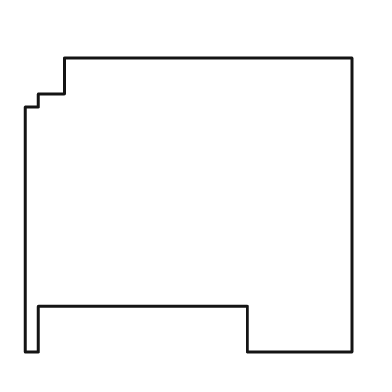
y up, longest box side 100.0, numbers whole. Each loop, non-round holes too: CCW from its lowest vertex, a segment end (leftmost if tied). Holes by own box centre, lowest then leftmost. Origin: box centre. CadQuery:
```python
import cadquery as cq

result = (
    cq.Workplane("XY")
    .moveTo(-50.0, -45.0)
    .lineTo(-46.0, -45.0)
    .lineTo(-46.0, -31.0)
    .lineTo(18.0, -31.0)
    .lineTo(18.0, -45.0)
    .lineTo(50.0, -45.0)
    .lineTo(50.0, 45.0)
    .lineTo(-38.0, 45.0)
    .lineTo(-38.0, 34.0)
    .lineTo(-46.0, 34.0)
    .lineTo(-46.0, 30.0)
    .lineTo(-50.0, 30.0)
    .close()
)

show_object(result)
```